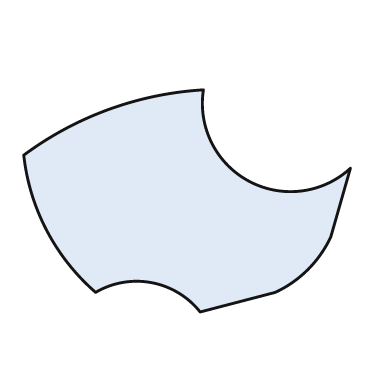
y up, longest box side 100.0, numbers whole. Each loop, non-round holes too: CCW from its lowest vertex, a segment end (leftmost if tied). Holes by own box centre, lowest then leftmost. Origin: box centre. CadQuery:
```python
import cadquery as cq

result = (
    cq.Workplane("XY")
    .moveTo(4.0, -34.0)
    .lineTo(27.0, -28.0)
    .threePointArc((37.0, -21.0), (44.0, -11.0))
    .lineTo(50.0, 10.0)
    .threePointArc((19.0, 6.0), (5.0, 34.0))
    .threePointArc((-24.0, 28.0), (-50.0, 14.0))
    .threePointArc((-43.0, -9.0), (-28.0, -28.0))
    .threePointArc((-11.0, -25.0), (4.0, -34.0))
    .close()
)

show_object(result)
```